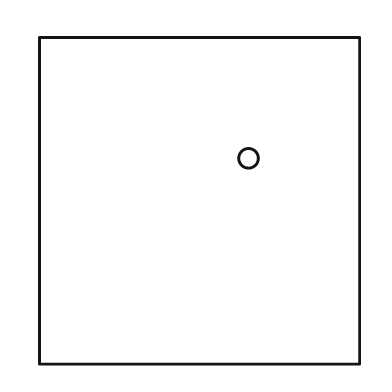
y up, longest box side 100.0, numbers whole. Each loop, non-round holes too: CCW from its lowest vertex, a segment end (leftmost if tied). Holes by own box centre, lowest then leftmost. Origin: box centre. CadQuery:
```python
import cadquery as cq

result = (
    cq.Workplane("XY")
    .moveTo(-49.0, -50.0)
    .lineTo(49.0, -50.0)
    .lineTo(49.0, 50.0)
    .lineTo(-49.0, 50.0)
    .close()
    .moveTo(15.0, 13.0)
    .circle(3.0)
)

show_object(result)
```